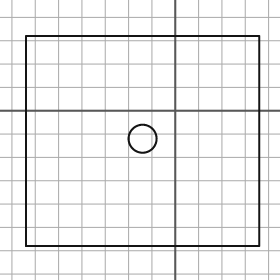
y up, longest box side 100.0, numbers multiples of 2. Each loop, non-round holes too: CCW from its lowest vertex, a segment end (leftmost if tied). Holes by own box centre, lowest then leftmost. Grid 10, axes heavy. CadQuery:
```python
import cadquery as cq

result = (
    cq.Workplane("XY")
    .moveTo(-64.0, -58.0)
    .lineTo(36.0, -58.0)
    .lineTo(36.0, 32.0)
    .lineTo(-64.0, 32.0)
    .close()
    .moveTo(-14.0, -12.0)
    .circle(6.0)
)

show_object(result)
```